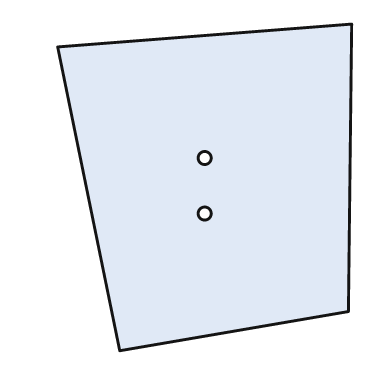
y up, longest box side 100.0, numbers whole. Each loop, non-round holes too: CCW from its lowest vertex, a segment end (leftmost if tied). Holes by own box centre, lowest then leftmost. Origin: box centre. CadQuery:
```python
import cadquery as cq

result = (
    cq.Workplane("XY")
    .moveTo(-26.0, -50.0)
    .lineTo(44.0, -38.0)
    .lineTo(45.0, 50.0)
    .lineTo(-45.0, 43.0)
    .close()
    .moveTo(0.0, -8.0)
    .circle(2.0)
    .moveTo(0.0, 9.0)
    .circle(2.0)
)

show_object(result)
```